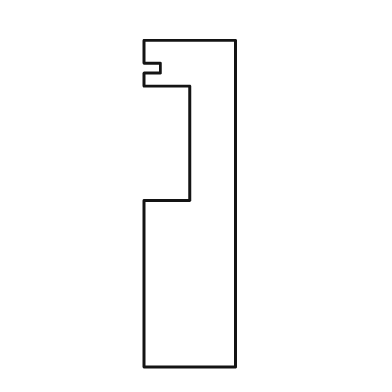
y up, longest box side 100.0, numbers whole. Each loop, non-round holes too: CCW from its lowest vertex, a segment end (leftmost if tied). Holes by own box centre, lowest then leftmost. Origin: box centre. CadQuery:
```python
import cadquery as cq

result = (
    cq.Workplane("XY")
    .moveTo(-14.0, -50.0)
    .lineTo(14.0, -50.0)
    .lineTo(14.0, 50.0)
    .lineTo(-14.0, 50.0)
    .lineTo(-14.0, 43.0)
    .lineTo(-9.0, 43.0)
    .lineTo(-9.0, 40.0)
    .lineTo(-14.0, 40.0)
    .lineTo(-14.0, 36.0)
    .lineTo(0.0, 36.0)
    .lineTo(0.0, 1.0)
    .lineTo(-14.0, 1.0)
    .close()
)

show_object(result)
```